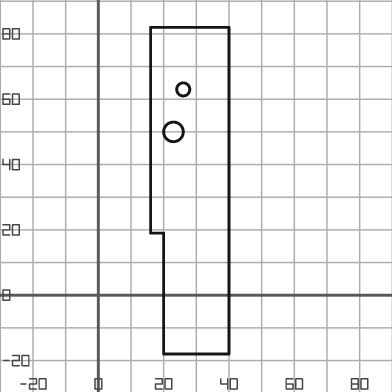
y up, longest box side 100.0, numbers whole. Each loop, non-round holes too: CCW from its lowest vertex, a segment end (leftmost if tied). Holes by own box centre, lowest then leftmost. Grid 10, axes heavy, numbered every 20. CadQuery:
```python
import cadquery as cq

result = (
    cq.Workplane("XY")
    .moveTo(20.0, -18.0)
    .lineTo(40.0, -18.0)
    .lineTo(40.0, 82.0)
    .lineTo(16.0, 82.0)
    .lineTo(16.0, 19.0)
    .lineTo(20.0, 19.0)
    .close()
    .moveTo(23.0, 50.0)
    .circle(3.0)
    .moveTo(26.0, 63.0)
    .circle(2.0)
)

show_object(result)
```